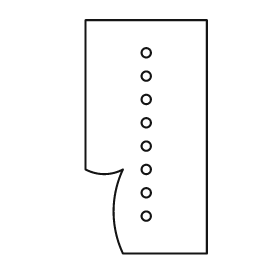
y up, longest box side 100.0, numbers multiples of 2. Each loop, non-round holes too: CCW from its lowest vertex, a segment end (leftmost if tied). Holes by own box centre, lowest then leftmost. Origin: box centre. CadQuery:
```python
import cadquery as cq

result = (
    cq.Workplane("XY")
    .moveTo(-10.0, -50.0)
    .lineTo(26.0, -50.0)
    .lineTo(26.0, 50.0)
    .lineTo(-26.0, 50.0)
    .lineTo(-26.0, -14.0)
    .threePointArc((-18.0, -16.0), (-10.0, -14.0))
    .threePointArc((-14.0, -32.0), (-10.0, -50.0))
    .close()
    .moveTo(0.0, -34.0)
    .circle(2.0)
    .moveTo(0.0, -24.0)
    .circle(2.0)
    .moveTo(0.0, -14.0)
    .circle(2.0)
    .moveTo(0.0, -4.0)
    .circle(2.0)
    .moveTo(0.0, 6.0)
    .circle(2.0)
    .moveTo(0.0, 16.0)
    .circle(2.0)
    .moveTo(0.0, 26.0)
    .circle(2.0)
    .moveTo(0.0, 36.0)
    .circle(2.0)
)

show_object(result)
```